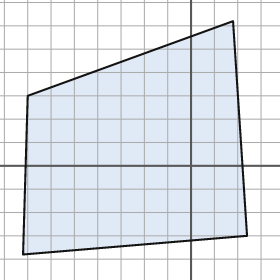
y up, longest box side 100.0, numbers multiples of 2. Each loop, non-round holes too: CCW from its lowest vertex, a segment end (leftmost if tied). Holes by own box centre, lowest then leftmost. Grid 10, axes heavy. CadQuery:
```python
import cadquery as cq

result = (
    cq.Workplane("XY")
    .moveTo(-72.0, -38.0)
    .lineTo(24.0, -30.0)
    .lineTo(18.0, 62.0)
    .lineTo(-70.0, 30.0)
    .close()
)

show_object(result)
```